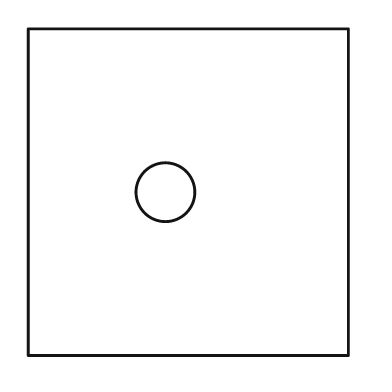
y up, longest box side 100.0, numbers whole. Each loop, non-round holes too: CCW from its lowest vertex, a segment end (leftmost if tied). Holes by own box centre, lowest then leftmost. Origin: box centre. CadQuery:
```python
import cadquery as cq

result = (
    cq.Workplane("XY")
    .moveTo(-49.0, -50.0)
    .lineTo(49.0, -50.0)
    .lineTo(49.0, 50.0)
    .lineTo(-49.0, 50.0)
    .close()
    .moveTo(-7.0, 0.0)
    .circle(9.0)
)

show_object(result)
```